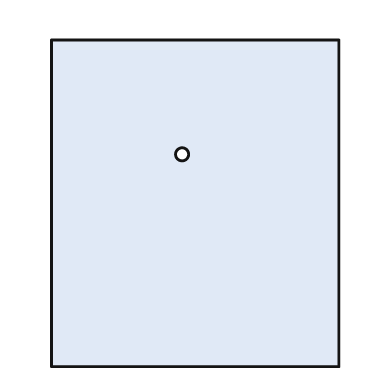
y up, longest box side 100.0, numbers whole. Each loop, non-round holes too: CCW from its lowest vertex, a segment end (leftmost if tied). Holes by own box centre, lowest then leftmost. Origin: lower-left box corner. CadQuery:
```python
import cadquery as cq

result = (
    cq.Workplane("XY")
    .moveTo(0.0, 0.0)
    .lineTo(88.0, 0.0)
    .lineTo(88.0, 100.0)
    .lineTo(0.0, 100.0)
    .close()
    .moveTo(40.0, 65.0)
    .circle(2.0)
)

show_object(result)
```